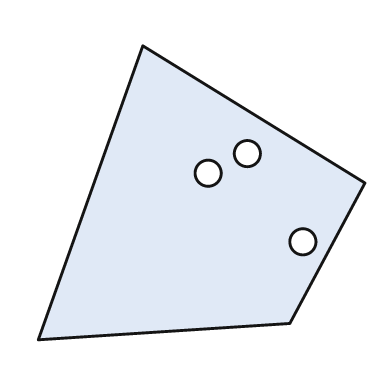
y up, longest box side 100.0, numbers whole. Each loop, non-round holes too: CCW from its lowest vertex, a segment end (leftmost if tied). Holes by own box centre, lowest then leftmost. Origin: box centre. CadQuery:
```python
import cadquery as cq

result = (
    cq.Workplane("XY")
    .moveTo(-50.0, -45.0)
    .lineTo(27.0, -40.0)
    .lineTo(50.0, 3.0)
    .lineTo(-18.0, 45.0)
    .close()
    .moveTo(31.0, -15.0)
    .circle(4.0)
    .moveTo(2.0, 6.0)
    .circle(4.0)
    .moveTo(14.0, 12.0)
    .circle(4.0)
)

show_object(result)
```